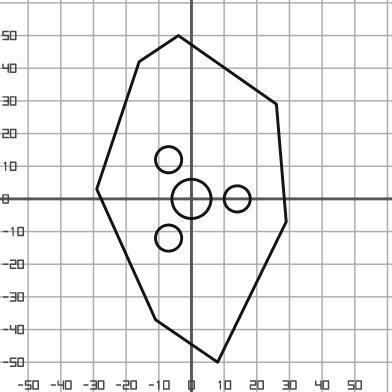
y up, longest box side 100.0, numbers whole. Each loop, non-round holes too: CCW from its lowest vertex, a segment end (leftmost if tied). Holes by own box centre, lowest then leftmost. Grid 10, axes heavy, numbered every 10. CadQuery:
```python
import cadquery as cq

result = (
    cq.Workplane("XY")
    .moveTo(8.0, -50.0)
    .lineTo(29.0, -7.0)
    .lineTo(26.0, 29.0)
    .lineTo(-4.0, 50.0)
    .lineTo(-16.0, 42.0)
    .lineTo(-29.0, 3.0)
    .lineTo(-11.0, -37.0)
    .close()
    .moveTo(-7.0, -12.0)
    .circle(4.0)
    .moveTo(0.0, 0.0)
    .circle(6.0)
    .moveTo(14.0, 0.0)
    .circle(4.0)
    .moveTo(-7.0, 12.0)
    .circle(4.0)
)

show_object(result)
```